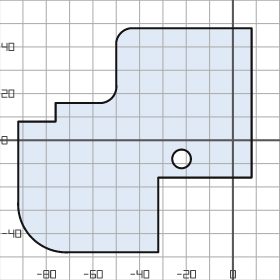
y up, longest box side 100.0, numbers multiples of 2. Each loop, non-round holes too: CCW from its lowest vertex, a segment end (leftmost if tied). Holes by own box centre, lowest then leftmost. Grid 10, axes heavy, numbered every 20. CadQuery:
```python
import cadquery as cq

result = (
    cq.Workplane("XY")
    .moveTo(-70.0, -48.0)
    .lineTo(-32.0, -48.0)
    .lineTo(-32.0, -16.0)
    .lineTo(8.0, -16.0)
    .lineTo(8.0, 48.0)
    .lineTo(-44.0, 48.0)
    .threePointArc((-48.0, 46.0), (-50.0, 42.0))
    .lineTo(-50.0, 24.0)
    .threePointArc((-52.0, 18.0), (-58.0, 16.0))
    .lineTo(-76.0, 16.0)
    .lineTo(-76.0, 8.0)
    .lineTo(-92.0, 8.0)
    .lineTo(-92.0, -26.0)
    .threePointArc((-86.0, -42.0), (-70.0, -48.0))
    .close()
    .moveTo(-22.0, -8.0)
    .circle(4.0)
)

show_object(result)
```